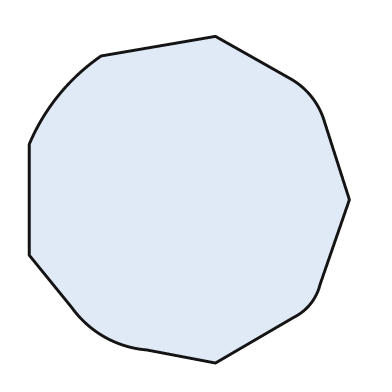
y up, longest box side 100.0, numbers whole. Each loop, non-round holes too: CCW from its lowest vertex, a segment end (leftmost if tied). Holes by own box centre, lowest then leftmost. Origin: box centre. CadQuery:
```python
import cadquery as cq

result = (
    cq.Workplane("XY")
    .moveTo(8.0, -50.0)
    .lineTo(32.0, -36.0)
    .threePointArc((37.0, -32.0), (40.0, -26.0))
    .lineTo(49.0, 0.0)
    .lineTo(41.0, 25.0)
    .threePointArc((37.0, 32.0), (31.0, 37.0))
    .lineTo(8.0, 50.0)
    .lineTo(-27.0, 44.0)
    .threePointArc((-40.0, 32.0), (-49.0, 17.0))
    .lineTo(-49.0, -17.0)
    .lineTo(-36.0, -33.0)
    .threePointArc((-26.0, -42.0), (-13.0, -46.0))
    .close()
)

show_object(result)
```